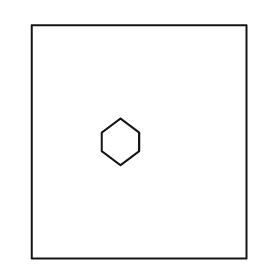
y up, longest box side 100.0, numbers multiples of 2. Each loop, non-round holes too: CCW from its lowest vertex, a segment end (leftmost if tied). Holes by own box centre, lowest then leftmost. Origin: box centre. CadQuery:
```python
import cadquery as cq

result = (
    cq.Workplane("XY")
    .moveTo(-46.0, -50.0)
    .lineTo(46.0, -50.0)
    .lineTo(46.0, 50.0)
    .lineTo(-46.0, 50.0)
    .close()
    .moveTo(-8.0, -10.0)
    .lineTo(0.0, -4.0)
    .lineTo(0.0, 4.0)
    .lineTo(-8.0, 10.0)
    .lineTo(-16.0, 4.0)
    .lineTo(-16.0, -4.0)
    .close()
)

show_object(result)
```